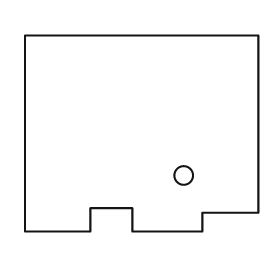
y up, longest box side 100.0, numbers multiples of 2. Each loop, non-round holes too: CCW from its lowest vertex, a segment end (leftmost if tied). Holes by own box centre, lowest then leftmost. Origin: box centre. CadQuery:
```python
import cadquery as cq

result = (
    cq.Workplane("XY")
    .moveTo(-50.0, -42.0)
    .lineTo(-22.0, -42.0)
    .lineTo(-22.0, -32.0)
    .lineTo(-4.0, -32.0)
    .lineTo(-4.0, -42.0)
    .lineTo(26.0, -42.0)
    .lineTo(26.0, -34.0)
    .lineTo(50.0, -34.0)
    .lineTo(50.0, 42.0)
    .lineTo(-50.0, 42.0)
    .close()
    .moveTo(18.0, -18.0)
    .circle(4.0)
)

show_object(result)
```